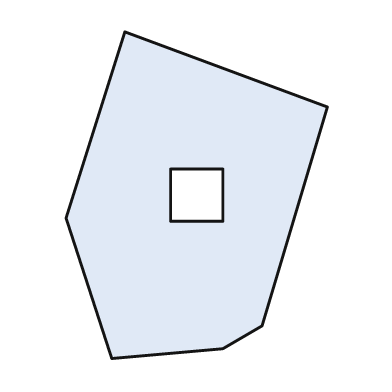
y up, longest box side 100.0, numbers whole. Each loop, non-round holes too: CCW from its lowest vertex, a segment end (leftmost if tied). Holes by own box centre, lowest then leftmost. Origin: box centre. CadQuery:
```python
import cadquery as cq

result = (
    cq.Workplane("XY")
    .moveTo(-26.0, -50.0)
    .lineTo(8.0, -47.0)
    .lineTo(20.0, -40.0)
    .lineTo(40.0, 27.0)
    .lineTo(-22.0, 50.0)
    .lineTo(-40.0, -7.0)
    .close()
    .moveTo(-8.0, -8.0)
    .lineTo(8.0, -8.0)
    .lineTo(8.0, 8.0)
    .lineTo(-8.0, 8.0)
    .close()
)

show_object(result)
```